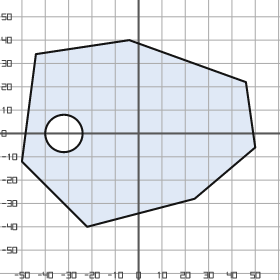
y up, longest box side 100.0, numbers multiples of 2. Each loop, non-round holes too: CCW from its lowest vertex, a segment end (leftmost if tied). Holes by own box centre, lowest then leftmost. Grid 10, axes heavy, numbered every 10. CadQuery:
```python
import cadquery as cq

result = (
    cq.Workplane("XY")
    .moveTo(-22.0, -40.0)
    .lineTo(24.0, -28.0)
    .lineTo(50.0, -6.0)
    .lineTo(46.0, 22.0)
    .lineTo(-4.0, 40.0)
    .lineTo(-44.0, 34.0)
    .lineTo(-50.0, -12.0)
    .close()
    .moveTo(-32.0, 0.0)
    .circle(8.0)
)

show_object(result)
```